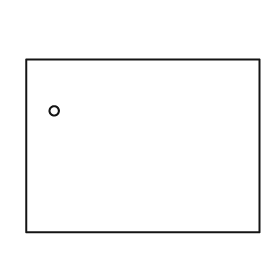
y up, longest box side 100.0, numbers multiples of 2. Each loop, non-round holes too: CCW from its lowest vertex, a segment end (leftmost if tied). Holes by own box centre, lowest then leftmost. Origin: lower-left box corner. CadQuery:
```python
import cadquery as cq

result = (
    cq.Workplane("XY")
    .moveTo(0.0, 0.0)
    .lineTo(100.0, 0.0)
    .lineTo(100.0, 74.0)
    .lineTo(0.0, 74.0)
    .close()
    .moveTo(12.0, 52.0)
    .circle(2.0)
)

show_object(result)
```